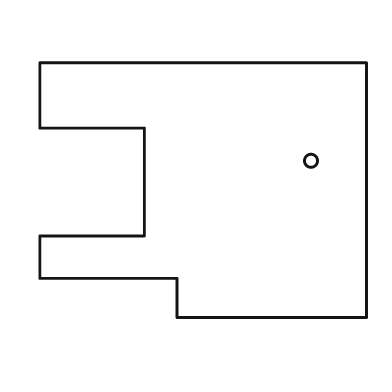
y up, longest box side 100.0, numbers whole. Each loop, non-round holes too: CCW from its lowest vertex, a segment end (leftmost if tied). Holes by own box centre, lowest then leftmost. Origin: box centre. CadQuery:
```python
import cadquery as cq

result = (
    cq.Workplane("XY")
    .moveTo(-8.0, -39.0)
    .lineTo(50.0, -39.0)
    .lineTo(50.0, 39.0)
    .lineTo(-50.0, 39.0)
    .lineTo(-50.0, 19.0)
    .lineTo(-18.0, 19.0)
    .lineTo(-18.0, -14.0)
    .lineTo(-50.0, -14.0)
    .lineTo(-50.0, -27.0)
    .lineTo(-8.0, -27.0)
    .close()
    .moveTo(33.0, 9.0)
    .circle(2.0)
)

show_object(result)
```